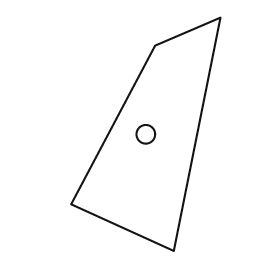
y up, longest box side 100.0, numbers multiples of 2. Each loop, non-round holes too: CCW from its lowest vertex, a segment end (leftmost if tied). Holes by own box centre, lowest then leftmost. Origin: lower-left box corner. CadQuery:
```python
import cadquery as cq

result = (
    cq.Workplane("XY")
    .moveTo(44.0, 0.0)
    .lineTo(64.0, 100.0)
    .lineTo(36.0, 88.0)
    .lineTo(0.0, 20.0)
    .close()
    .moveTo(32.0, 50.0)
    .circle(4.0)
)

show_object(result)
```